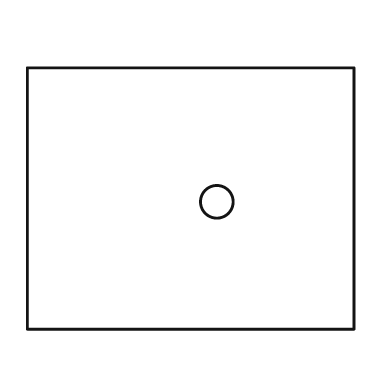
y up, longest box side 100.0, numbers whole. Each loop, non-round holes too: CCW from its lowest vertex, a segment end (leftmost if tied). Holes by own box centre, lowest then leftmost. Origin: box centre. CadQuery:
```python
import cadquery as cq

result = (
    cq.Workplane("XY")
    .moveTo(-50.0, -40.0)
    .lineTo(50.0, -40.0)
    .lineTo(50.0, 40.0)
    .lineTo(-50.0, 40.0)
    .close()
    .moveTo(8.0, -1.0)
    .circle(5.0)
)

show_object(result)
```